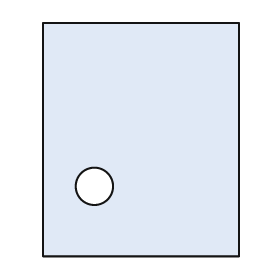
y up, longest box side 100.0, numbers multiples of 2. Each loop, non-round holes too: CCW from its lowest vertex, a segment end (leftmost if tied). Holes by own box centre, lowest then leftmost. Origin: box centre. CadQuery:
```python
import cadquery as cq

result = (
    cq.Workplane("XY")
    .moveTo(-42.0, -50.0)
    .lineTo(42.0, -50.0)
    .lineTo(42.0, 50.0)
    .lineTo(-42.0, 50.0)
    .close()
    .moveTo(-20.0, -20.0)
    .circle(8.0)
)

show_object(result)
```